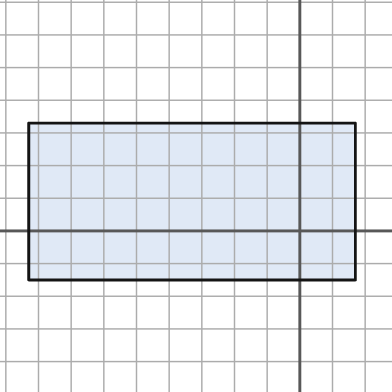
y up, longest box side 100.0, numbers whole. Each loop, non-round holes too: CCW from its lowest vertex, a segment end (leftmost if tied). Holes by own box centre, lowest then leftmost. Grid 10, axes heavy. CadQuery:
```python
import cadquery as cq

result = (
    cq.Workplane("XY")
    .moveTo(-83.0, -15.0)
    .lineTo(17.0, -15.0)
    .lineTo(17.0, 33.0)
    .lineTo(-83.0, 33.0)
    .close()
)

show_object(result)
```